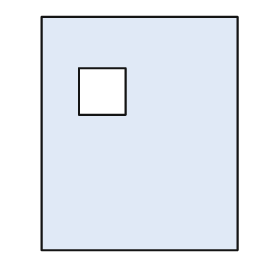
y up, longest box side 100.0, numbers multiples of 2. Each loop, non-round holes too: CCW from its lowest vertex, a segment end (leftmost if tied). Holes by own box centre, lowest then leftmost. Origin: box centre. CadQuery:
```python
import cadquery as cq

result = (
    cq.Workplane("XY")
    .moveTo(-42.0, -50.0)
    .lineTo(42.0, -50.0)
    .lineTo(42.0, 50.0)
    .lineTo(-42.0, 50.0)
    .close()
    .moveTo(-26.0, 8.0)
    .lineTo(-6.0, 8.0)
    .lineTo(-6.0, 28.0)
    .lineTo(-26.0, 28.0)
    .close()
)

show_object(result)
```